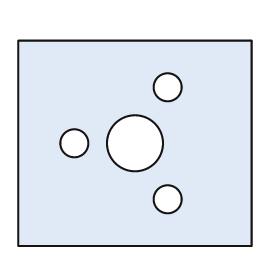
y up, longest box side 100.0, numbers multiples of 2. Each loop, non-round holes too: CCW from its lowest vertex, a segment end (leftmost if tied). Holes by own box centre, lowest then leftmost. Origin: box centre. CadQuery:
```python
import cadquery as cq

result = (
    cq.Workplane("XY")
    .moveTo(-50.0, -44.0)
    .lineTo(50.0, -44.0)
    .lineTo(50.0, 44.0)
    .lineTo(-50.0, 44.0)
    .close()
    .moveTo(14.0, -24.0)
    .circle(6.0)
    .moveTo(-26.0, 0.0)
    .circle(6.0)
    .moveTo(0.0, 0.0)
    .circle(12.0)
    .moveTo(14.0, 24.0)
    .circle(6.0)
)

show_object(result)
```